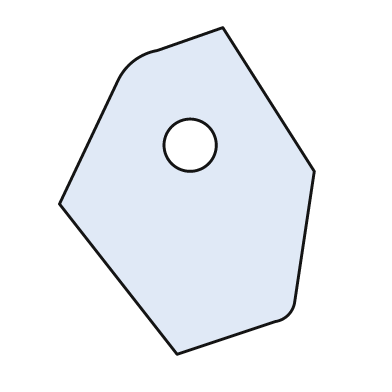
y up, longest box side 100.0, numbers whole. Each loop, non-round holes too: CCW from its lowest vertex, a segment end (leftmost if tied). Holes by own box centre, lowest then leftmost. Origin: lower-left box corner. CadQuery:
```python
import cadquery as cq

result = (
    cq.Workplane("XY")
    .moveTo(36.0, 0.0)
    .lineTo(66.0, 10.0)
    .threePointArc((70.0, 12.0), (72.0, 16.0))
    .lineTo(78.0, 56.0)
    .lineTo(50.0, 100.0)
    .lineTo(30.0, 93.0)
    .threePointArc((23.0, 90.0), (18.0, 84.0))
    .lineTo(0.0, 46.0)
    .close()
    .moveTo(40.0, 64.0)
    .circle(8.0)
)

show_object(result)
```